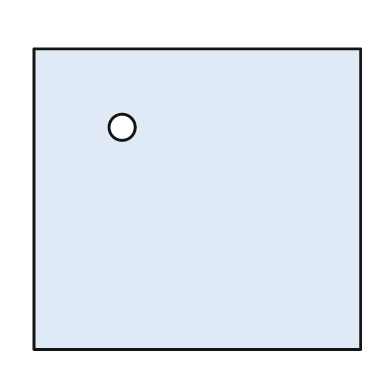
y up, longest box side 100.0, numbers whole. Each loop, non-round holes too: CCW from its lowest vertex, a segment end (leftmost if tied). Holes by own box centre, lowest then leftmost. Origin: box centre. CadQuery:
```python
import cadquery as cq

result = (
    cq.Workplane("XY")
    .moveTo(-50.0, -46.0)
    .lineTo(50.0, -46.0)
    .lineTo(50.0, 46.0)
    .lineTo(-50.0, 46.0)
    .close()
    .moveTo(-23.0, 22.0)
    .circle(4.0)
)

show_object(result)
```